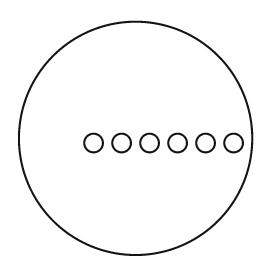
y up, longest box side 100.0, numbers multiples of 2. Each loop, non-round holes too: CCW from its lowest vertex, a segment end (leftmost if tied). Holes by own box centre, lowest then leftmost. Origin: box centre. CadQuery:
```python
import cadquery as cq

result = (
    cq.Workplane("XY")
    .moveTo(0.0, 0.0)
    .circle(50.0)
    .moveTo(-18.0, -2.0)
    .circle(4.0)
    .moveTo(-6.0, -2.0)
    .circle(4.0)
    .moveTo(6.0, -2.0)
    .circle(4.0)
    .moveTo(18.0, -2.0)
    .circle(4.0)
    .moveTo(30.0, -2.0)
    .circle(4.0)
    .moveTo(42.0, -2.0)
    .circle(4.0)
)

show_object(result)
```